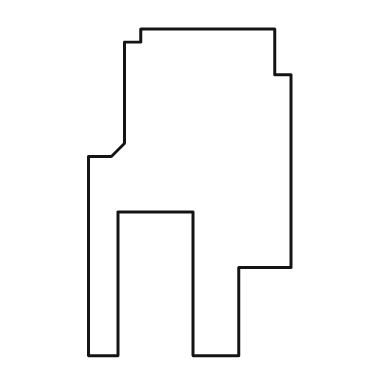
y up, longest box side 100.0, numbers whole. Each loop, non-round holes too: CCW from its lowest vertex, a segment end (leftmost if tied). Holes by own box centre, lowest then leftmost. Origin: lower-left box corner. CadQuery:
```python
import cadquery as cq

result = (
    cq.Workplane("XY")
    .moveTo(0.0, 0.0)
    .lineTo(9.0, 0.0)
    .lineTo(9.0, 44.0)
    .lineTo(32.0, 44.0)
    .lineTo(32.0, 0.0)
    .lineTo(46.0, 0.0)
    .lineTo(46.0, 27.0)
    .lineTo(62.0, 27.0)
    .lineTo(62.0, 86.0)
    .lineTo(57.0, 86.0)
    .lineTo(57.0, 100.0)
    .lineTo(16.0, 100.0)
    .lineTo(16.0, 96.0)
    .lineTo(11.0, 96.0)
    .lineTo(11.0, 65.0)
    .lineTo(7.0, 61.0)
    .lineTo(0.0, 61.0)
    .close()
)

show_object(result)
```